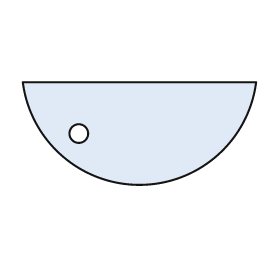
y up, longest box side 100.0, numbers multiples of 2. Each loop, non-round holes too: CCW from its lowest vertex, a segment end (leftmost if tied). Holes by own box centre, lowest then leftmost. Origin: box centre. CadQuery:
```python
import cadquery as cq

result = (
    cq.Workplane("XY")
    .moveTo(-50.0, 22.0)
    .threePointArc((0.0, -22.0), (50.0, 22.0))
    .close()
    .moveTo(-26.0, 0.0)
    .circle(4.0)
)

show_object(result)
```